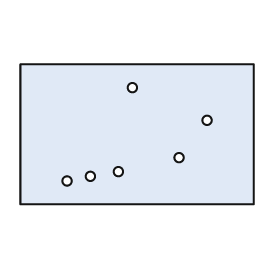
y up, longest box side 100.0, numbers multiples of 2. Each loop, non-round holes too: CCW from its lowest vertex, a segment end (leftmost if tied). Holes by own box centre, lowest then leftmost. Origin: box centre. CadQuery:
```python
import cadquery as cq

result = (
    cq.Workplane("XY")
    .moveTo(-50.0, -30.0)
    .lineTo(50.0, -30.0)
    .lineTo(50.0, 30.0)
    .lineTo(-50.0, 30.0)
    .close()
    .moveTo(-30.0, -20.0)
    .circle(2.0)
    .moveTo(-20.0, -18.0)
    .circle(2.0)
    .moveTo(-8.0, -16.0)
    .circle(2.0)
    .moveTo(18.0, -10.0)
    .circle(2.0)
    .moveTo(30.0, 6.0)
    .circle(2.0)
    .moveTo(-2.0, 20.0)
    .circle(2.0)
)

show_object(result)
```